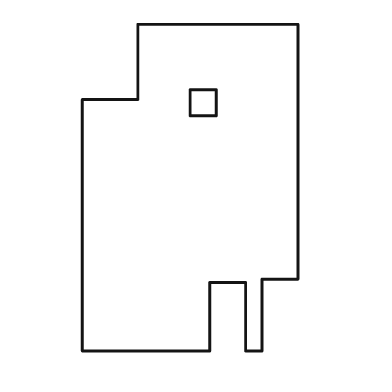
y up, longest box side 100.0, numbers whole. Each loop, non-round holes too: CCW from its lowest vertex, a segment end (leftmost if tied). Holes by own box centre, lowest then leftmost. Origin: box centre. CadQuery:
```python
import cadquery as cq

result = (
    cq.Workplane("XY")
    .moveTo(-33.0, -50.0)
    .lineTo(6.0, -50.0)
    .lineTo(6.0, -29.0)
    .lineTo(17.0, -29.0)
    .lineTo(17.0, -50.0)
    .lineTo(22.0, -50.0)
    .lineTo(22.0, -28.0)
    .lineTo(33.0, -28.0)
    .lineTo(33.0, 50.0)
    .lineTo(-16.0, 50.0)
    .lineTo(-16.0, 27.0)
    .lineTo(-33.0, 27.0)
    .close()
    .moveTo(0.0, 22.0)
    .lineTo(8.0, 22.0)
    .lineTo(8.0, 30.0)
    .lineTo(0.0, 30.0)
    .close()
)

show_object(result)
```